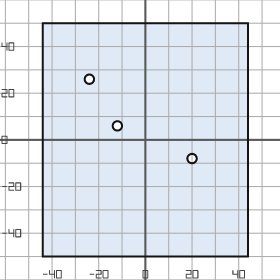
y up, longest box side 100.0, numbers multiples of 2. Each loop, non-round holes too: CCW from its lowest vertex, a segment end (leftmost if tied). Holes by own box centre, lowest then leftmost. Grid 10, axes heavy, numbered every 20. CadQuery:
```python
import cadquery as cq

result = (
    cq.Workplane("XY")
    .moveTo(-44.0, -50.0)
    .lineTo(44.0, -50.0)
    .lineTo(44.0, 50.0)
    .lineTo(-44.0, 50.0)
    .close()
    .moveTo(20.0, -8.0)
    .circle(2.0)
    .moveTo(-12.0, 6.0)
    .circle(2.0)
    .moveTo(-24.0, 26.0)
    .circle(2.0)
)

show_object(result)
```